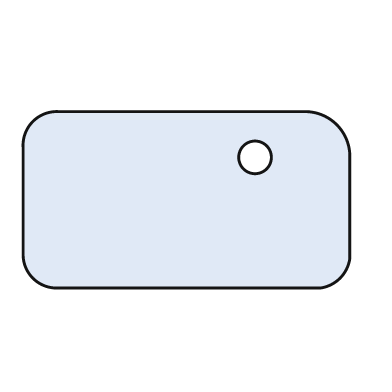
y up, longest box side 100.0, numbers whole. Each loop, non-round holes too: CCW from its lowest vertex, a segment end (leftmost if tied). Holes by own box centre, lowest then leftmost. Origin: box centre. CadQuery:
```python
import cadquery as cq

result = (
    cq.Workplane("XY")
    .moveTo(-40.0, -27.0)
    .lineTo(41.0, -27.0)
    .threePointArc((47.0, -24.0), (50.0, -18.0))
    .lineTo(50.0, 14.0)
    .threePointArc((46.0, 23.0), (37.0, 27.0))
    .lineTo(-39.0, 27.0)
    .threePointArc((-47.0, 24.0), (-50.0, 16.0))
    .lineTo(-50.0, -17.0)
    .threePointArc((-47.0, -24.0), (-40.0, -27.0))
    .close()
    .moveTo(21.0, 13.0)
    .circle(5.0)
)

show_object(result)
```